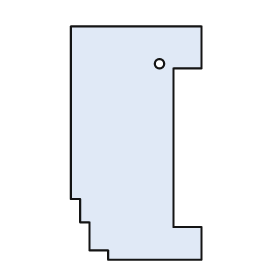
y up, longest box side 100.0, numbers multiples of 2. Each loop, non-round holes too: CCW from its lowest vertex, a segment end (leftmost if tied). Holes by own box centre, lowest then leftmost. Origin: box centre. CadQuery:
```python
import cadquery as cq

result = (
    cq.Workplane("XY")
    .moveTo(-12.0, -50.0)
    .lineTo(28.0, -50.0)
    .lineTo(28.0, -36.0)
    .lineTo(16.0, -36.0)
    .lineTo(16.0, 32.0)
    .lineTo(28.0, 32.0)
    .lineTo(28.0, 50.0)
    .lineTo(-28.0, 50.0)
    .lineTo(-28.0, -24.0)
    .lineTo(-24.0, -24.0)
    .lineTo(-24.0, -34.0)
    .lineTo(-20.0, -34.0)
    .lineTo(-20.0, -46.0)
    .lineTo(-12.0, -46.0)
    .close()
    .moveTo(10.0, 34.0)
    .circle(2.0)
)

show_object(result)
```